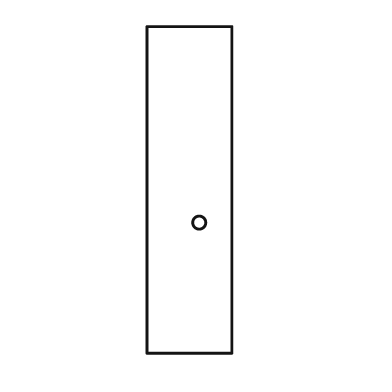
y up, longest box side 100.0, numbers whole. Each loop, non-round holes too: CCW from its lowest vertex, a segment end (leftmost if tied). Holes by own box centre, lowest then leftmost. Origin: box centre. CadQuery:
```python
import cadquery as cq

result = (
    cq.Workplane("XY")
    .moveTo(-13.0, -50.0)
    .lineTo(13.0, -50.0)
    .lineTo(13.0, 50.0)
    .lineTo(-13.0, 50.0)
    .close()
    .moveTo(3.0, -10.0)
    .circle(2.0)
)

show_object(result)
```